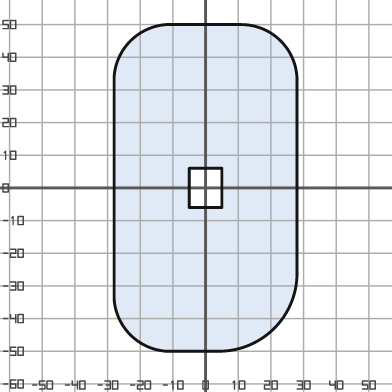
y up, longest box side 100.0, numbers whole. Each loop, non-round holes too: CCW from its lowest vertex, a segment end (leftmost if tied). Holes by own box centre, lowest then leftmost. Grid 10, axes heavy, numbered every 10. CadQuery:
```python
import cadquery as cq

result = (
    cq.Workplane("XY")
    .moveTo(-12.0, -50.0)
    .lineTo(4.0, -50.0)
    .threePointArc((21.0, -43.0), (28.0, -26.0))
    .lineTo(28.0, 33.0)
    .threePointArc((23.0, 45.0), (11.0, 50.0))
    .lineTo(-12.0, 50.0)
    .threePointArc((-23.0, 45.0), (-28.0, 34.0))
    .lineTo(-28.0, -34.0)
    .threePointArc((-23.0, -45.0), (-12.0, -50.0))
    .close()
    .moveTo(-5.0, -6.0)
    .lineTo(5.0, -6.0)
    .lineTo(5.0, 6.0)
    .lineTo(-5.0, 6.0)
    .close()
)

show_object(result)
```